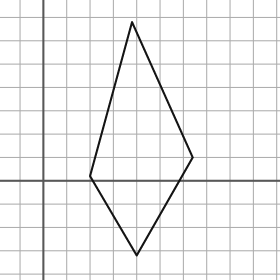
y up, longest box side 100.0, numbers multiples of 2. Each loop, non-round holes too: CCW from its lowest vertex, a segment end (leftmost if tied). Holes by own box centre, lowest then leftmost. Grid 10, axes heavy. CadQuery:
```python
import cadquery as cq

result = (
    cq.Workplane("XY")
    .moveTo(40.0, -32.0)
    .lineTo(64.0, 10.0)
    .lineTo(38.0, 68.0)
    .lineTo(20.0, 2.0)
    .close()
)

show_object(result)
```